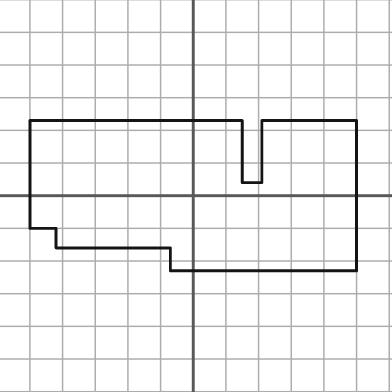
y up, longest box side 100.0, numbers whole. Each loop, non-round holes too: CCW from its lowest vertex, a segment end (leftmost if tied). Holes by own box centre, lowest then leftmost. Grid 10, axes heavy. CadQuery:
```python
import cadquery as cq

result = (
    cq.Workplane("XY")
    .moveTo(-7.0, -23.0)
    .lineTo(50.0, -23.0)
    .lineTo(50.0, 23.0)
    .lineTo(21.0, 23.0)
    .lineTo(21.0, 4.0)
    .lineTo(15.0, 4.0)
    .lineTo(15.0, 23.0)
    .lineTo(-50.0, 23.0)
    .lineTo(-50.0, -10.0)
    .lineTo(-42.0, -10.0)
    .lineTo(-42.0, -16.0)
    .lineTo(-7.0, -16.0)
    .close()
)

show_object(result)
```